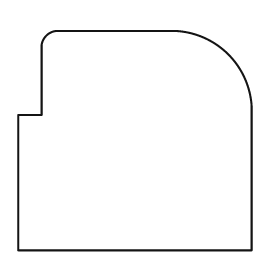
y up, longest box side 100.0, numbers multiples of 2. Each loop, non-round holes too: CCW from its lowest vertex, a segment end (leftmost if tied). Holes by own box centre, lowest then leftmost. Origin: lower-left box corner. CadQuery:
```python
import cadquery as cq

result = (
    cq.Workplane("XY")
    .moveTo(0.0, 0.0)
    .lineTo(100.0, 0.0)
    .lineTo(100.0, 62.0)
    .threePointArc((90.0, 84.0), (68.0, 94.0))
    .lineTo(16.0, 94.0)
    .threePointArc((12.0, 92.0), (10.0, 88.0))
    .lineTo(10.0, 58.0)
    .lineTo(0.0, 58.0)
    .close()
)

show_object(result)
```